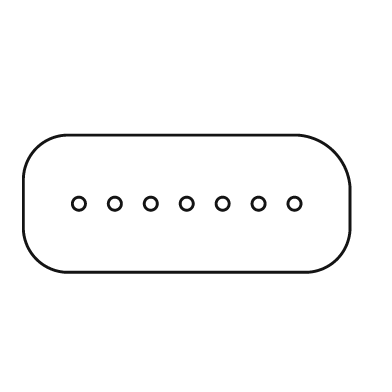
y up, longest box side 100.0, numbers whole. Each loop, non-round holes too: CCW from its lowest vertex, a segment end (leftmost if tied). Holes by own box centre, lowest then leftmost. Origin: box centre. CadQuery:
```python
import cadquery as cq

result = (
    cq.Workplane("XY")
    .moveTo(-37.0, -21.0)
    .lineTo(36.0, -21.0)
    .threePointArc((46.0, -17.0), (50.0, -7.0))
    .lineTo(50.0, 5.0)
    .threePointArc((45.0, 16.0), (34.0, 21.0))
    .lineTo(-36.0, 21.0)
    .threePointArc((-46.0, 17.0), (-50.0, 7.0))
    .lineTo(-50.0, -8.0)
    .threePointArc((-46.0, -17.0), (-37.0, -21.0))
    .close()
    .moveTo(-33.0, 0.0)
    .circle(2.0)
    .moveTo(-22.0, 0.0)
    .circle(2.0)
    .moveTo(-11.0, 0.0)
    .circle(2.0)
    .moveTo(0.0, 0.0)
    .circle(2.0)
    .moveTo(11.0, 0.0)
    .circle(2.0)
    .moveTo(22.0, 0.0)
    .circle(2.0)
    .moveTo(33.0, 0.0)
    .circle(2.0)
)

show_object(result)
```